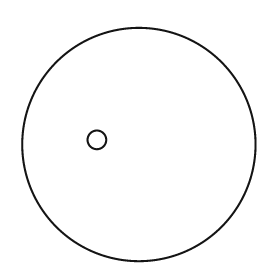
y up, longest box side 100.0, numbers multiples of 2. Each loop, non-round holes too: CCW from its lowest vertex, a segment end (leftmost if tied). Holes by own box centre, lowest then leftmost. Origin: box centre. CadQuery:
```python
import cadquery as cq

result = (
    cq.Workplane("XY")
    .moveTo(0.0, 0.0)
    .circle(50.0)
    .moveTo(-18.0, 2.0)
    .circle(4.0)
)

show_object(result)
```